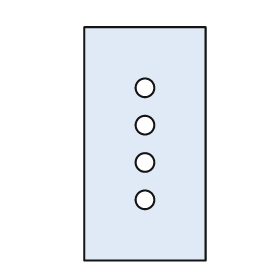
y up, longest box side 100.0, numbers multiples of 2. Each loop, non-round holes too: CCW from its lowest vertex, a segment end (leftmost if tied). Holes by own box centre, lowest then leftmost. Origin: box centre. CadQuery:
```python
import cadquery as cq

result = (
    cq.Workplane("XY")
    .moveTo(-26.0, -50.0)
    .lineTo(26.0, -50.0)
    .lineTo(26.0, 50.0)
    .lineTo(-26.0, 50.0)
    .close()
    .moveTo(0.0, -24.0)
    .circle(4.0)
    .moveTo(0.0, -8.0)
    .circle(4.0)
    .moveTo(0.0, 8.0)
    .circle(4.0)
    .moveTo(0.0, 24.0)
    .circle(4.0)
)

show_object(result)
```